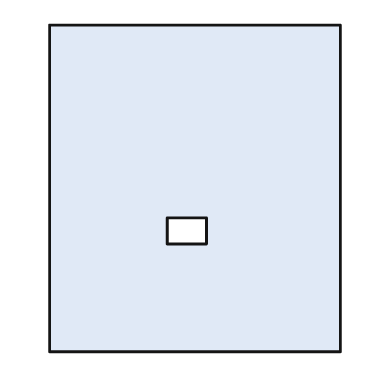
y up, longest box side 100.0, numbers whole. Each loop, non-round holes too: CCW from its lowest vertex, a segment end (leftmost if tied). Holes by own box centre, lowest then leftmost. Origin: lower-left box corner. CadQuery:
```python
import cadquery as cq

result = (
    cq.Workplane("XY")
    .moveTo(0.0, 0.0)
    .lineTo(89.0, 0.0)
    .lineTo(89.0, 100.0)
    .lineTo(0.0, 100.0)
    .close()
    .moveTo(36.0, 33.0)
    .lineTo(48.0, 33.0)
    .lineTo(48.0, 41.0)
    .lineTo(36.0, 41.0)
    .close()
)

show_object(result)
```